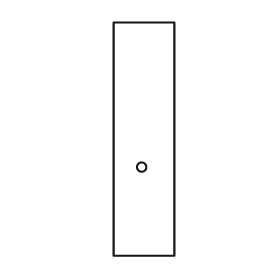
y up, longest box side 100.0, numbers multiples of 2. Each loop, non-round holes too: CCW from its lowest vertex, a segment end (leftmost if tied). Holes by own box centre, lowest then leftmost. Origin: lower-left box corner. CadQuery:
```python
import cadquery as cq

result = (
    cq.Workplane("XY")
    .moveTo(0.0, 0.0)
    .lineTo(26.0, 0.0)
    .lineTo(26.0, 100.0)
    .lineTo(0.0, 100.0)
    .close()
    .moveTo(12.0, 38.0)
    .circle(2.0)
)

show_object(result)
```